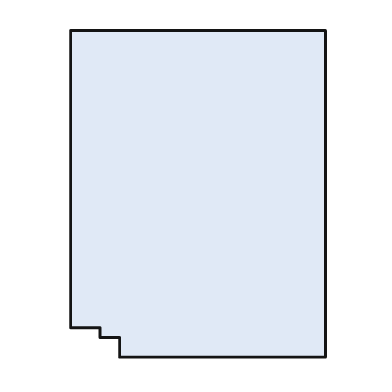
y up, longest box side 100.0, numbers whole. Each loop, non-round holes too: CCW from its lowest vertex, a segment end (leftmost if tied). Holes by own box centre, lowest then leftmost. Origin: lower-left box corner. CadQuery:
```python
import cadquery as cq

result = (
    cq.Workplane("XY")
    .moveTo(15.0, 0.0)
    .lineTo(78.0, 0.0)
    .lineTo(78.0, 100.0)
    .lineTo(0.0, 100.0)
    .lineTo(0.0, 9.0)
    .lineTo(9.0, 9.0)
    .lineTo(9.0, 6.0)
    .lineTo(15.0, 6.0)
    .close()
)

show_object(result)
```